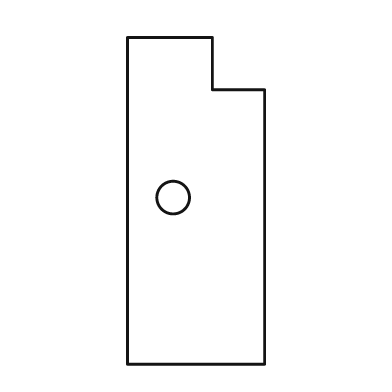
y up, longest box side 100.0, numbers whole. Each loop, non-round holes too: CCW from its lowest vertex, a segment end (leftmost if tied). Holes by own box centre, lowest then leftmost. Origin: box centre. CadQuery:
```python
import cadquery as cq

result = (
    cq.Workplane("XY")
    .moveTo(-21.0, -50.0)
    .lineTo(21.0, -50.0)
    .lineTo(21.0, 34.0)
    .lineTo(5.0, 34.0)
    .lineTo(5.0, 50.0)
    .lineTo(-21.0, 50.0)
    .close()
    .moveTo(-7.0, 1.0)
    .circle(5.0)
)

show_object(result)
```